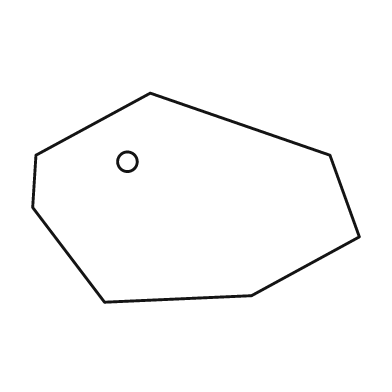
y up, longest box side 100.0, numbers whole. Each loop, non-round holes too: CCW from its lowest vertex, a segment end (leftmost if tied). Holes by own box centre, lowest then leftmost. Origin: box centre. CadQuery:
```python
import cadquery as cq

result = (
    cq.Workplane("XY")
    .moveTo(-28.0, -32.0)
    .lineTo(17.0, -30.0)
    .lineTo(50.0, -12.0)
    .lineTo(41.0, 13.0)
    .lineTo(-14.0, 32.0)
    .lineTo(-49.0, 13.0)
    .lineTo(-50.0, -3.0)
    .close()
    .moveTo(-21.0, 11.0)
    .circle(3.0)
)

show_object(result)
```